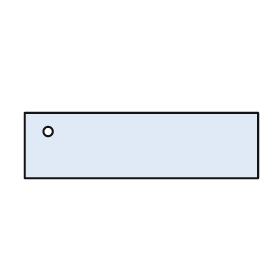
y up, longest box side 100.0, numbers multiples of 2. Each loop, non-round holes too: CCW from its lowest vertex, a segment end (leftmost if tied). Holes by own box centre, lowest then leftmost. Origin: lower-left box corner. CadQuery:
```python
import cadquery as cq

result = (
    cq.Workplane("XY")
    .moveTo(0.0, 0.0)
    .lineTo(100.0, 0.0)
    .lineTo(100.0, 28.0)
    .lineTo(0.0, 28.0)
    .close()
    .moveTo(10.0, 20.0)
    .circle(2.0)
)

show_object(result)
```